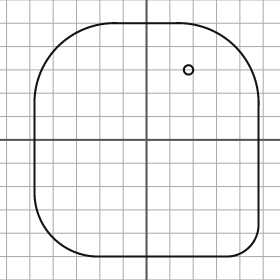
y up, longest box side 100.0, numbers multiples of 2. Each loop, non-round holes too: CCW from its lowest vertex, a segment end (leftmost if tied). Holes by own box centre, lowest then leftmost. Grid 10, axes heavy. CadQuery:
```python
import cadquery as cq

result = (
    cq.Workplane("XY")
    .moveTo(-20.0, -50.0)
    .lineTo(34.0, -50.0)
    .threePointArc((44.0, -46.0), (48.0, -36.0))
    .lineTo(48.0, 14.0)
    .threePointArc((38.0, 40.0), (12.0, 50.0))
    .lineTo(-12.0, 50.0)
    .threePointArc((-38.0, 40.0), (-48.0, 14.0))
    .lineTo(-48.0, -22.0)
    .threePointArc((-40.0, -42.0), (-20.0, -50.0))
    .close()
    .moveTo(18.0, 30.0)
    .circle(2.0)
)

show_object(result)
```